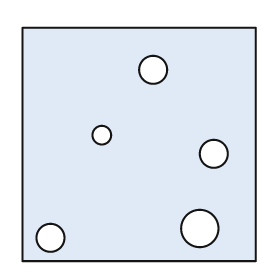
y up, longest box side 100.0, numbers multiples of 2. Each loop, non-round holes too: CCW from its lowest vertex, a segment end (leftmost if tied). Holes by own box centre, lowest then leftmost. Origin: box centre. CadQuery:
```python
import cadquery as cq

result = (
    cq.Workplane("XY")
    .moveTo(-50.0, -50.0)
    .lineTo(50.0, -50.0)
    .lineTo(50.0, 50.0)
    .lineTo(-50.0, 50.0)
    .close()
    .moveTo(-38.0, -40.0)
    .circle(6.0)
    .moveTo(26.0, -36.0)
    .circle(8.0)
    .moveTo(32.0, -4.0)
    .circle(6.0)
    .moveTo(-16.0, 4.0)
    .circle(4.0)
    .moveTo(6.0, 32.0)
    .circle(6.0)
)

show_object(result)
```